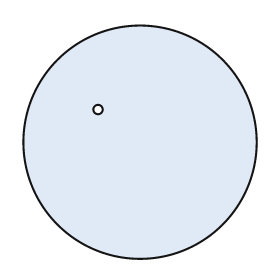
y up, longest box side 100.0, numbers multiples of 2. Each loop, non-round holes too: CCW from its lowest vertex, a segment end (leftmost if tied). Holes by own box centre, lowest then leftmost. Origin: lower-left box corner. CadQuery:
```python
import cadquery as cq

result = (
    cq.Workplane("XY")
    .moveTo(50.0, 50.0)
    .circle(50.0)
    .moveTo(32.0, 64.0)
    .circle(2.0)
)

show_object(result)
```